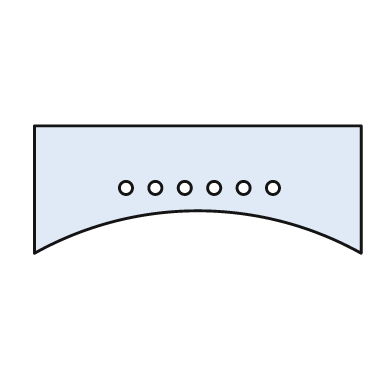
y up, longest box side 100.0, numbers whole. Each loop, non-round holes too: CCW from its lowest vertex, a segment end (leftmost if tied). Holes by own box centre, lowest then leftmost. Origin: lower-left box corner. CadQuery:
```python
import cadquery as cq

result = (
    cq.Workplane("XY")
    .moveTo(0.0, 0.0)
    .threePointArc((50.0, 13.0), (100.0, 0.0))
    .lineTo(100.0, 39.0)
    .lineTo(0.0, 39.0)
    .close()
    .moveTo(28.0, 20.0)
    .circle(2.0)
    .moveTo(37.0, 20.0)
    .circle(2.0)
    .moveTo(46.0, 20.0)
    .circle(2.0)
    .moveTo(55.0, 20.0)
    .circle(2.0)
    .moveTo(64.0, 20.0)
    .circle(2.0)
    .moveTo(73.0, 20.0)
    .circle(2.0)
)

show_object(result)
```